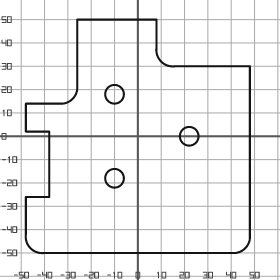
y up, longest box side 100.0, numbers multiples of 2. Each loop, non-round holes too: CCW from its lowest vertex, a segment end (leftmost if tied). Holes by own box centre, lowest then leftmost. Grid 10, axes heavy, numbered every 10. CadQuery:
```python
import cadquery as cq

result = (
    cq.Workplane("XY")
    .moveTo(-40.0, -50.0)
    .lineTo(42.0, -50.0)
    .threePointArc((46.0, -48.0), (48.0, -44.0))
    .lineTo(48.0, 30.0)
    .lineTo(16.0, 30.0)
    .threePointArc((10.0, 32.0), (8.0, 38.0))
    .lineTo(8.0, 50.0)
    .lineTo(-26.0, 50.0)
    .lineTo(-26.0, 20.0)
    .threePointArc((-28.0, 16.0), (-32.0, 14.0))
    .lineTo(-48.0, 14.0)
    .lineTo(-48.0, 2.0)
    .lineTo(-38.0, 2.0)
    .lineTo(-38.0, -26.0)
    .lineTo(-48.0, -26.0)
    .lineTo(-48.0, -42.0)
    .threePointArc((-46.0, -48.0), (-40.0, -50.0))
    .close()
    .moveTo(-10.0, -18.0)
    .circle(4.0)
    .moveTo(22.0, 0.0)
    .circle(4.0)
    .moveTo(-10.0, 18.0)
    .circle(4.0)
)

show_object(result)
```